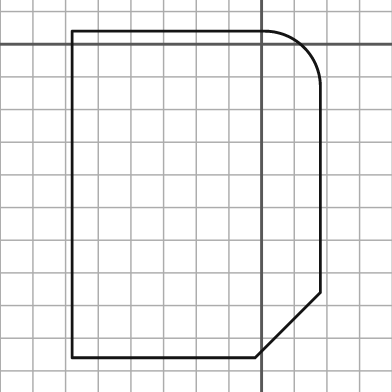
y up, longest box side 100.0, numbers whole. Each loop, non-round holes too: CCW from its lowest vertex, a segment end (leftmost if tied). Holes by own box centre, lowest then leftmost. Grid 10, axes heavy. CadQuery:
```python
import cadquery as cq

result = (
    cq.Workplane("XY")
    .moveTo(-58.0, -96.0)
    .lineTo(-2.0, -96.0)
    .lineTo(18.0, -76.0)
    .lineTo(18.0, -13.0)
    .threePointArc((13.0, -1.0), (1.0, 4.0))
    .lineTo(-58.0, 4.0)
    .close()
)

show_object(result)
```